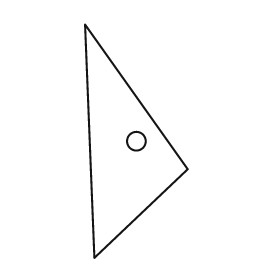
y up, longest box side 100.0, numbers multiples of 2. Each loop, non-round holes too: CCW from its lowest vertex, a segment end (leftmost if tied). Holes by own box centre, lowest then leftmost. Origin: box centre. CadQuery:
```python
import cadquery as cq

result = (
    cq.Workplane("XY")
    .moveTo(-18.0, -50.0)
    .lineTo(22.0, -12.0)
    .lineTo(-22.0, 50.0)
    .close()
    .moveTo(0.0, 0.0)
    .circle(4.0)
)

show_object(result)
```